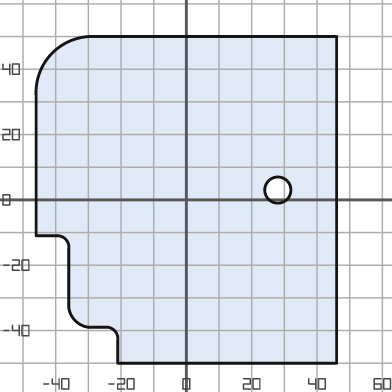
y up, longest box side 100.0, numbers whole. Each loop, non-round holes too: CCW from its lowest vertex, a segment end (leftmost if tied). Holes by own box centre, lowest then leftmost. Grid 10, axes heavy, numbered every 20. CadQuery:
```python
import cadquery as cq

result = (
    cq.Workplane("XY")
    .moveTo(-21.0, -50.0)
    .lineTo(46.0, -50.0)
    .lineTo(46.0, 50.0)
    .lineTo(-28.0, 50.0)
    .threePointArc((-41.0, 45.0), (-46.0, 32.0))
    .lineTo(-46.0, -11.0)
    .lineTo(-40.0, -11.0)
    .threePointArc((-37.0, -12.0), (-36.0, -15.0))
    .lineTo(-36.0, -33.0)
    .threePointArc((-34.0, -37.0), (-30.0, -39.0))
    .lineTo(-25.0, -39.0)
    .threePointArc((-22.0, -40.0), (-21.0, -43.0))
    .close()
    .moveTo(28.0, 3.0)
    .circle(4.0)
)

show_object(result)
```